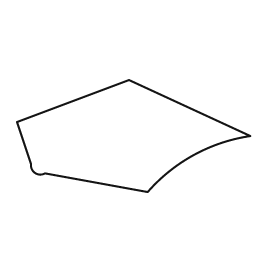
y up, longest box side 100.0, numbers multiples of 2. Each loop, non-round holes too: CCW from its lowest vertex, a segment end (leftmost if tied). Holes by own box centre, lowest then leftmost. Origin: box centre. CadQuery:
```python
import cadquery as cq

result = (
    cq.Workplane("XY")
    .moveTo(6.0, -24.0)
    .threePointArc((26.0, -8.0), (50.0, 0.0))
    .lineTo(-2.0, 24.0)
    .lineTo(-50.0, 6.0)
    .lineTo(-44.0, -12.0)
    .threePointArc((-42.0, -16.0), (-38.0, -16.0))
    .close()
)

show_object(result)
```